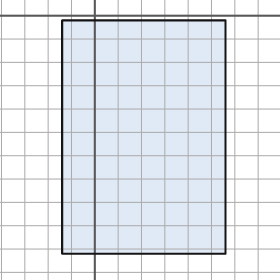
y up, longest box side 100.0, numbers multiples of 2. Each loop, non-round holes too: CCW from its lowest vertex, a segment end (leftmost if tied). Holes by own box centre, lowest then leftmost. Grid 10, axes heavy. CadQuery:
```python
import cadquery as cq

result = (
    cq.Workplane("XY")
    .moveTo(-14.0, -102.0)
    .lineTo(56.0, -102.0)
    .lineTo(56.0, -2.0)
    .lineTo(-14.0, -2.0)
    .close()
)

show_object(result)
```